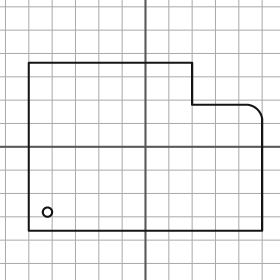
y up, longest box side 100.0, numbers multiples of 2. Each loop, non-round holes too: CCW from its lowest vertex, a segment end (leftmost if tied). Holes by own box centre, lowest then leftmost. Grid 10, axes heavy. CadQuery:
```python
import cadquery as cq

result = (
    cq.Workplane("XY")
    .moveTo(-50.0, -36.0)
    .lineTo(50.0, -36.0)
    .lineTo(50.0, 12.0)
    .threePointArc((48.0, 16.0), (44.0, 18.0))
    .lineTo(20.0, 18.0)
    .lineTo(20.0, 36.0)
    .lineTo(-50.0, 36.0)
    .close()
    .moveTo(-42.0, -28.0)
    .circle(2.0)
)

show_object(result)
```